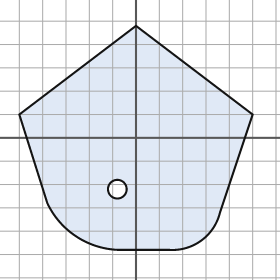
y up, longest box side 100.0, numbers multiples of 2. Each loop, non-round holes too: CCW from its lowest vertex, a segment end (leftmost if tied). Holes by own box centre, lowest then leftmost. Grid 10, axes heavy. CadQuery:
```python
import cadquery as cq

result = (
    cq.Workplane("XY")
    .moveTo(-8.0, -48.0)
    .lineTo(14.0, -48.0)
    .threePointArc((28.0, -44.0), (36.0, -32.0))
    .lineTo(50.0, 10.0)
    .lineTo(0.0, 48.0)
    .lineTo(-50.0, 10.0)
    .lineTo(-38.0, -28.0)
    .threePointArc((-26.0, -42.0), (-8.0, -48.0))
    .close()
    .moveTo(-8.0, -22.0)
    .circle(4.0)
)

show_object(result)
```